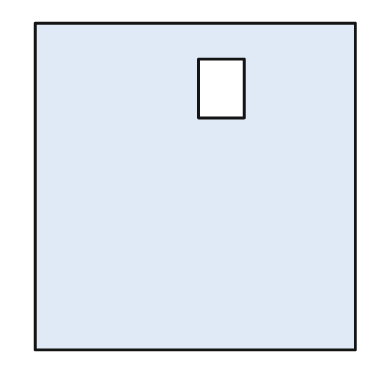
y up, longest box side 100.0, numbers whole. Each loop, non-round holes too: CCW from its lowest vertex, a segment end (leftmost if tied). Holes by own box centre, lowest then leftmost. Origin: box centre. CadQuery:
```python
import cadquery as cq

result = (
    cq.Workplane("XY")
    .moveTo(-49.0, -50.0)
    .lineTo(49.0, -50.0)
    .lineTo(49.0, 50.0)
    .lineTo(-49.0, 50.0)
    .close()
    .moveTo(1.0, 21.0)
    .lineTo(15.0, 21.0)
    .lineTo(15.0, 39.0)
    .lineTo(1.0, 39.0)
    .close()
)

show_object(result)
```